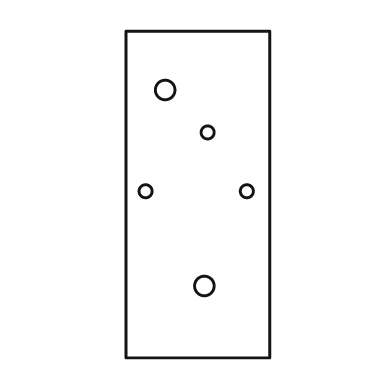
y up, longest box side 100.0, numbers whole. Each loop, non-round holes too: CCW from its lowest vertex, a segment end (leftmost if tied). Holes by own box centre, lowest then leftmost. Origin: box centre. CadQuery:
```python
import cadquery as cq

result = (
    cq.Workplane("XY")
    .moveTo(-22.0, -50.0)
    .lineTo(22.0, -50.0)
    .lineTo(22.0, 50.0)
    .lineTo(-22.0, 50.0)
    .close()
    .moveTo(2.0, -28.0)
    .circle(3.0)
    .moveTo(-16.0, 1.0)
    .circle(2.0)
    .moveTo(15.0, 1.0)
    .circle(2.0)
    .moveTo(3.0, 19.0)
    .circle(2.0)
    .moveTo(-10.0, 32.0)
    .circle(3.0)
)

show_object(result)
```